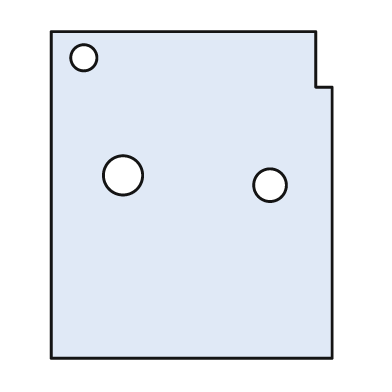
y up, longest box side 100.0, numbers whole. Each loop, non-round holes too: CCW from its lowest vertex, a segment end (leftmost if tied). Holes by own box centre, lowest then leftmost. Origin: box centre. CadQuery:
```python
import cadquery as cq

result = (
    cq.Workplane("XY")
    .moveTo(-43.0, -50.0)
    .lineTo(43.0, -50.0)
    .lineTo(43.0, 33.0)
    .lineTo(38.0, 33.0)
    .lineTo(38.0, 50.0)
    .lineTo(-43.0, 50.0)
    .close()
    .moveTo(24.0, 3.0)
    .circle(5.0)
    .moveTo(-21.0, 6.0)
    .circle(6.0)
    .moveTo(-33.0, 42.0)
    .circle(4.0)
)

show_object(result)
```